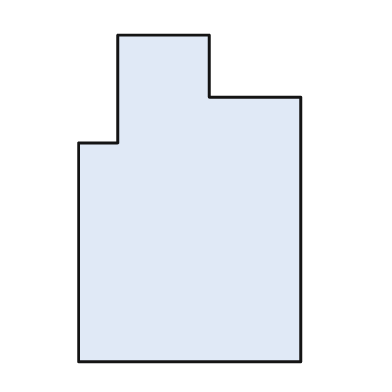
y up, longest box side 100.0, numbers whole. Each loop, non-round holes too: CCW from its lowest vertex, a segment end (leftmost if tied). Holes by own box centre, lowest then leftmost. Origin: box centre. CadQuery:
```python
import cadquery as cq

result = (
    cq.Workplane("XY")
    .moveTo(-34.0, -50.0)
    .lineTo(34.0, -50.0)
    .lineTo(34.0, 31.0)
    .lineTo(6.0, 31.0)
    .lineTo(6.0, 50.0)
    .lineTo(-22.0, 50.0)
    .lineTo(-22.0, 17.0)
    .lineTo(-34.0, 17.0)
    .close()
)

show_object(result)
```